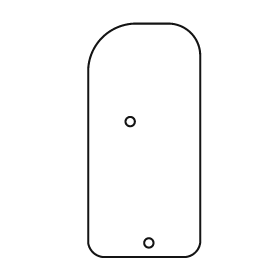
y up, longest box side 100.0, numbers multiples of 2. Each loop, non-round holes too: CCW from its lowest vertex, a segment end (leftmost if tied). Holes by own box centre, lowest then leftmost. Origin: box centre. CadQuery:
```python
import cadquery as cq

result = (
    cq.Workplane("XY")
    .moveTo(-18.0, -50.0)
    .lineTo(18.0, -50.0)
    .threePointArc((22.0, -48.0), (24.0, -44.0))
    .lineTo(24.0, 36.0)
    .threePointArc((20.0, 46.0), (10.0, 50.0))
    .lineTo(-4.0, 50.0)
    .threePointArc((-18.0, 44.0), (-24.0, 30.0))
    .lineTo(-24.0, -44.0)
    .threePointArc((-22.0, -48.0), (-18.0, -50.0))
    .close()
    .moveTo(2.0, -44.0)
    .circle(2.0)
    .moveTo(-6.0, 8.0)
    .circle(2.0)
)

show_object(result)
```